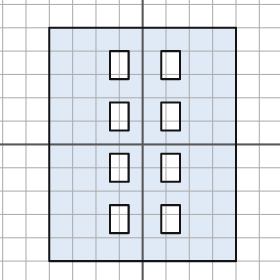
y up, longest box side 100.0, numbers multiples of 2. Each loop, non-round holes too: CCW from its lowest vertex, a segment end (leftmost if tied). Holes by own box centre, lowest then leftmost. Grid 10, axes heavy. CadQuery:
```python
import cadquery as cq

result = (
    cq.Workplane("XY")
    .moveTo(-40.0, -50.0)
    .lineTo(40.0, -50.0)
    .lineTo(40.0, 50.0)
    .lineTo(-40.0, 50.0)
    .close()
    .moveTo(-14.0, -38.0)
    .lineTo(-6.0, -38.0)
    .lineTo(-6.0, -26.0)
    .lineTo(-14.0, -26.0)
    .close()
    .moveTo(8.0, -38.0)
    .lineTo(16.0, -38.0)
    .lineTo(16.0, -26.0)
    .lineTo(8.0, -26.0)
    .close()
    .moveTo(-14.0, -16.0)
    .lineTo(-6.0, -16.0)
    .lineTo(-6.0, -4.0)
    .lineTo(-14.0, -4.0)
    .close()
    .moveTo(8.0, -16.0)
    .lineTo(16.0, -16.0)
    .lineTo(16.0, -4.0)
    .lineTo(8.0, -4.0)
    .close()
    .moveTo(-14.0, 6.0)
    .lineTo(-6.0, 6.0)
    .lineTo(-6.0, 18.0)
    .lineTo(-14.0, 18.0)
    .close()
    .moveTo(8.0, 6.0)
    .lineTo(16.0, 6.0)
    .lineTo(16.0, 18.0)
    .lineTo(8.0, 18.0)
    .close()
    .moveTo(-14.0, 28.0)
    .lineTo(-6.0, 28.0)
    .lineTo(-6.0, 40.0)
    .lineTo(-14.0, 40.0)
    .close()
    .moveTo(8.0, 28.0)
    .lineTo(16.0, 28.0)
    .lineTo(16.0, 40.0)
    .lineTo(8.0, 40.0)
    .close()
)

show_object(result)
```